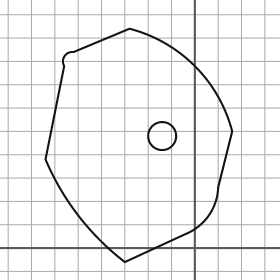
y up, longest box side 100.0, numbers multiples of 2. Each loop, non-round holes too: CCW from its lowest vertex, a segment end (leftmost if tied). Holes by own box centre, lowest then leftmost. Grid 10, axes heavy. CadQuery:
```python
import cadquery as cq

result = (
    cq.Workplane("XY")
    .moveTo(-30.0, -6.0)
    .lineTo(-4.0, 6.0)
    .threePointArc((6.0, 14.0), (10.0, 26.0))
    .lineTo(16.0, 50.0)
    .threePointArc((0.0, 78.0), (-28.0, 94.0))
    .lineTo(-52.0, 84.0)
    .threePointArc((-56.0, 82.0), (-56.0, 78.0))
    .lineTo(-64.0, 38.0)
    .threePointArc((-50.0, 14.0), (-30.0, -6.0))
    .close()
    .moveTo(-14.0, 48.0)
    .circle(6.0)
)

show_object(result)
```